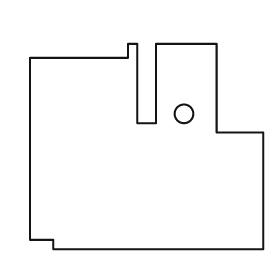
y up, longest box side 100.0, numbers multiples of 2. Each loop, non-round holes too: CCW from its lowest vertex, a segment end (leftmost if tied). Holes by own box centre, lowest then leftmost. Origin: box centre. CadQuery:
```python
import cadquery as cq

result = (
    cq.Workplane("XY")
    .moveTo(-40.0, -44.0)
    .lineTo(50.0, -44.0)
    .lineTo(50.0, 6.0)
    .lineTo(30.0, 6.0)
    .lineTo(30.0, 44.0)
    .lineTo(4.0, 44.0)
    .lineTo(4.0, 10.0)
    .lineTo(-4.0, 10.0)
    .lineTo(-4.0, 44.0)
    .lineTo(-8.0, 44.0)
    .lineTo(-8.0, 38.0)
    .lineTo(-50.0, 38.0)
    .lineTo(-50.0, -40.0)
    .lineTo(-40.0, -40.0)
    .close()
    .moveTo(16.0, 14.0)
    .circle(4.0)
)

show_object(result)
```